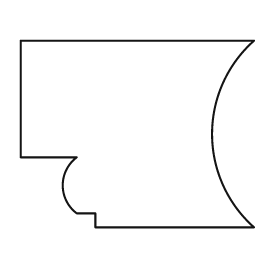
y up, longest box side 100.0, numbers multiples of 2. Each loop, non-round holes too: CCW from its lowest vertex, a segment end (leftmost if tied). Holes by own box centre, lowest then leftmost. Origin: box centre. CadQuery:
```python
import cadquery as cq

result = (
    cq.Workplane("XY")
    .moveTo(-18.0, -40.0)
    .lineTo(50.0, -40.0)
    .threePointArc((32.0, 0.0), (50.0, 40.0))
    .lineTo(-50.0, 40.0)
    .lineTo(-50.0, -10.0)
    .lineTo(-26.0, -10.0)
    .threePointArc((-32.0, -22.0), (-26.0, -34.0))
    .lineTo(-18.0, -34.0)
    .close()
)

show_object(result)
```